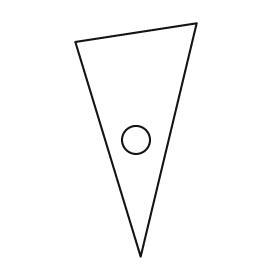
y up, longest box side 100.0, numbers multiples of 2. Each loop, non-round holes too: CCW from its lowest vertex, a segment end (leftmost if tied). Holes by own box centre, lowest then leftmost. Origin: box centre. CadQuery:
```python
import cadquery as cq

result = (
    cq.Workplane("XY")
    .moveTo(2.0, -50.0)
    .lineTo(26.0, 50.0)
    .lineTo(-26.0, 42.0)
    .close()
    .moveTo(0.0, 0.0)
    .circle(6.0)
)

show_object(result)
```